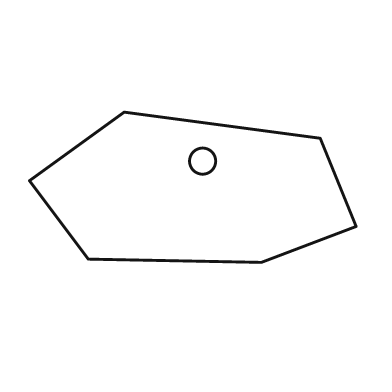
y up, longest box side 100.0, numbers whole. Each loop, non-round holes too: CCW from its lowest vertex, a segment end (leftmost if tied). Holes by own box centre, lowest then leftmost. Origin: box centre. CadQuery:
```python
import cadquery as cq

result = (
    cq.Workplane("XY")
    .moveTo(21.0, -23.0)
    .lineTo(50.0, -12.0)
    .lineTo(39.0, 15.0)
    .lineTo(-21.0, 23.0)
    .lineTo(-50.0, 2.0)
    .lineTo(-32.0, -22.0)
    .close()
    .moveTo(3.0, 8.0)
    .circle(4.0)
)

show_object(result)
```